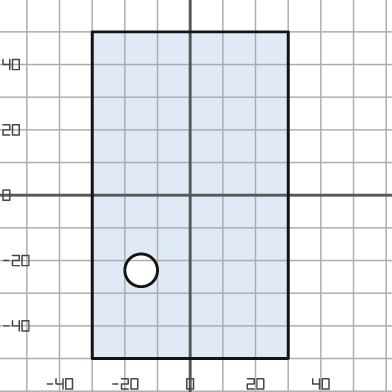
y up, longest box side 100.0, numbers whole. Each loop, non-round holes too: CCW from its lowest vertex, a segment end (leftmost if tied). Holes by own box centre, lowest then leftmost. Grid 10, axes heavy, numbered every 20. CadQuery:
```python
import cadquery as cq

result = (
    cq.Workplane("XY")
    .moveTo(-30.0, -50.0)
    .lineTo(30.0, -50.0)
    .lineTo(30.0, 50.0)
    .lineTo(-30.0, 50.0)
    .close()
    .moveTo(-15.0, -23.0)
    .circle(5.0)
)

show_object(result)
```